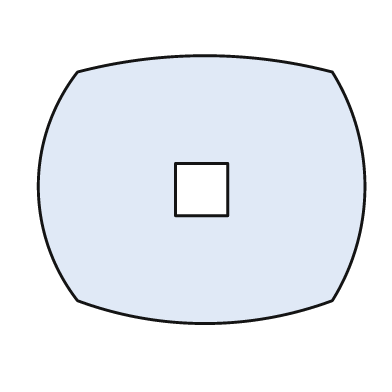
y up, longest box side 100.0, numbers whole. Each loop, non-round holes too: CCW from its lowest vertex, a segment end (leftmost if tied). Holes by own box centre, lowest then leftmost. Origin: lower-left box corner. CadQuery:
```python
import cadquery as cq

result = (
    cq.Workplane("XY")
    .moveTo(12.0, 7.0)
    .threePointArc((51.0, 0.0), (90.0, 7.0))
    .threePointArc((100.0, 42.0), (90.0, 77.0))
    .threePointArc((51.0, 82.0), (12.0, 77.0))
    .threePointArc((0.0, 42.0), (12.0, 7.0))
    .close()
    .moveTo(42.0, 33.0)
    .lineTo(58.0, 33.0)
    .lineTo(58.0, 49.0)
    .lineTo(42.0, 49.0)
    .close()
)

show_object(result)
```